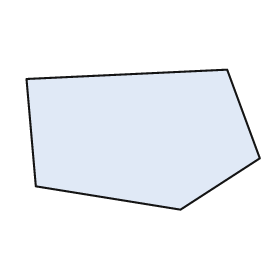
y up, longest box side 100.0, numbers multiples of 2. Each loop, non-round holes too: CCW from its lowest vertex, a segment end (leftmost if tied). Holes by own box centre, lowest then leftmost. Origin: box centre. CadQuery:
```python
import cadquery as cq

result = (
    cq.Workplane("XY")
    .moveTo(16.0, -30.0)
    .lineTo(50.0, -8.0)
    .lineTo(36.0, 30.0)
    .lineTo(-50.0, 26.0)
    .lineTo(-46.0, -20.0)
    .close()
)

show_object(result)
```